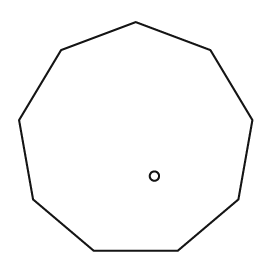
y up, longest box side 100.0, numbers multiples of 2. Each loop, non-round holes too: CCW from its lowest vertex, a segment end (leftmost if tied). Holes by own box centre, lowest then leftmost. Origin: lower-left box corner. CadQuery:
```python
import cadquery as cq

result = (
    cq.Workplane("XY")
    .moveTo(32.0, 0.0)
    .lineTo(68.0, 0.0)
    .lineTo(94.0, 22.0)
    .lineTo(100.0, 56.0)
    .lineTo(82.0, 86.0)
    .lineTo(50.0, 98.0)
    .lineTo(18.0, 86.0)
    .lineTo(0.0, 56.0)
    .lineTo(6.0, 22.0)
    .close()
    .moveTo(58.0, 32.0)
    .circle(2.0)
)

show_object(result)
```